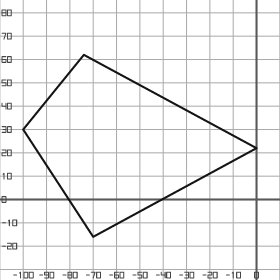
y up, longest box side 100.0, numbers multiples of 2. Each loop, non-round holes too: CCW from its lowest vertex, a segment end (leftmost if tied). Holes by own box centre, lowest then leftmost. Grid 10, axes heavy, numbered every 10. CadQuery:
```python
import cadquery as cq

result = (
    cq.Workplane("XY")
    .moveTo(-70.0, -16.0)
    .lineTo(0.0, 22.0)
    .lineTo(-74.0, 62.0)
    .lineTo(-100.0, 30.0)
    .close()
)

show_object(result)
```